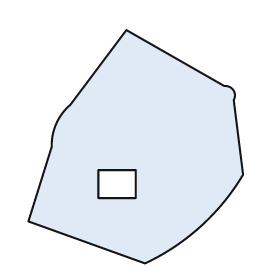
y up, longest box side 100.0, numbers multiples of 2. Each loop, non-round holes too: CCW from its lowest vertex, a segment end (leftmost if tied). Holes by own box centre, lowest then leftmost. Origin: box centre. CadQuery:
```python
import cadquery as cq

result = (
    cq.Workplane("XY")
    .moveTo(4.0, -50.0)
    .threePointArc((28.0, -34.0), (46.0, -12.0))
    .lineTo(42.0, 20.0)
    .threePointArc((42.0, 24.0), (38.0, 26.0))
    .lineTo(-4.0, 50.0)
    .lineTo(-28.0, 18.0)
    .threePointArc((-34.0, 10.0), (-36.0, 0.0))
    .lineTo(-46.0, -32.0)
    .close()
    .moveTo(-16.0, -22.0)
    .lineTo(0.0, -22.0)
    .lineTo(0.0, -10.0)
    .lineTo(-16.0, -10.0)
    .close()
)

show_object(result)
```